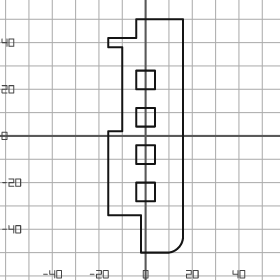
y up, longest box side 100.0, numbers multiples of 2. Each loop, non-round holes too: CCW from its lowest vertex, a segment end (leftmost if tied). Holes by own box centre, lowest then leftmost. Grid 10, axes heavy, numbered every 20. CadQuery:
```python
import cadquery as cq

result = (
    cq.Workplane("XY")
    .moveTo(-2.0, -50.0)
    .lineTo(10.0, -50.0)
    .threePointArc((14.0, -48.0), (16.0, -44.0))
    .lineTo(16.0, 50.0)
    .lineTo(-4.0, 50.0)
    .lineTo(-4.0, 42.0)
    .lineTo(-16.0, 42.0)
    .lineTo(-16.0, 38.0)
    .lineTo(-10.0, 38.0)
    .lineTo(-10.0, 2.0)
    .lineTo(-16.0, 2.0)
    .lineTo(-16.0, -34.0)
    .lineTo(-2.0, -34.0)
    .close()
    .moveTo(-4.0, -28.0)
    .lineTo(4.0, -28.0)
    .lineTo(4.0, -20.0)
    .lineTo(-4.0, -20.0)
    .close()
    .moveTo(-4.0, -12.0)
    .lineTo(4.0, -12.0)
    .lineTo(4.0, -4.0)
    .lineTo(-4.0, -4.0)
    .close()
    .moveTo(-4.0, 4.0)
    .lineTo(4.0, 4.0)
    .lineTo(4.0, 12.0)
    .lineTo(-4.0, 12.0)
    .close()
    .moveTo(-4.0, 20.0)
    .lineTo(4.0, 20.0)
    .lineTo(4.0, 28.0)
    .lineTo(-4.0, 28.0)
    .close()
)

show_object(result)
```